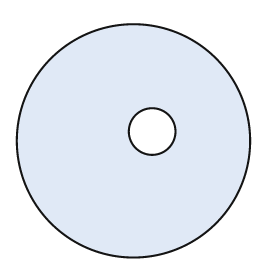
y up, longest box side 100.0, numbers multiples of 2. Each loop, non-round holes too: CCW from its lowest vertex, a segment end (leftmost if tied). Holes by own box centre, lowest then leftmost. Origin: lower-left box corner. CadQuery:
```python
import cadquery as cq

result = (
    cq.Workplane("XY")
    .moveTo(50.0, 50.0)
    .circle(50.0)
    .moveTo(58.0, 54.0)
    .circle(10.0)
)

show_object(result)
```